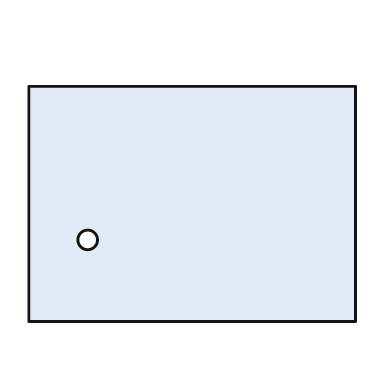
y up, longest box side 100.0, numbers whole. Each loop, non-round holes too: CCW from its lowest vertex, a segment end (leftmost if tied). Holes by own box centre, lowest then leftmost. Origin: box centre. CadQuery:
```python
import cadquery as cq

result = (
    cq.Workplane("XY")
    .moveTo(-50.0, -36.0)
    .lineTo(50.0, -36.0)
    .lineTo(50.0, 36.0)
    .lineTo(-50.0, 36.0)
    .close()
    .moveTo(-32.0, -11.0)
    .circle(3.0)
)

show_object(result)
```